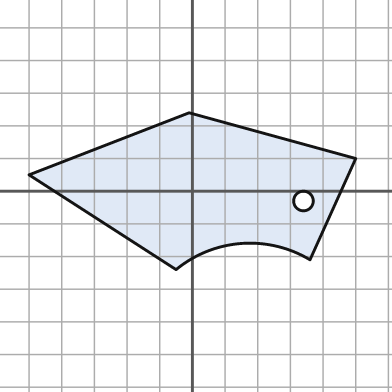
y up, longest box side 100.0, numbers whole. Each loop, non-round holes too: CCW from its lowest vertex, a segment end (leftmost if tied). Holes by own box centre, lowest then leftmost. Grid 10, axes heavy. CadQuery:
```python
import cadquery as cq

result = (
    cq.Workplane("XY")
    .moveTo(-5.0, -24.0)
    .threePointArc((15.0, -16.0), (36.0, -21.0))
    .lineTo(50.0, 10.0)
    .lineTo(-1.0, 24.0)
    .lineTo(-50.0, 5.0)
    .close()
    .moveTo(34.0, -3.0)
    .circle(3.0)
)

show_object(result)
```